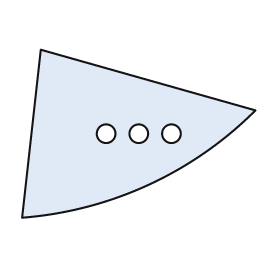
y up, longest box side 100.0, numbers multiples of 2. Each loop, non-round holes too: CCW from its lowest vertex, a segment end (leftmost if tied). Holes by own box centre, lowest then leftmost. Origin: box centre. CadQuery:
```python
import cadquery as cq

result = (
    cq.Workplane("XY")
    .moveTo(-50.0, -36.0)
    .threePointArc((4.0, -22.0), (50.0, 10.0))
    .lineTo(-42.0, 36.0)
    .close()
    .moveTo(-14.0, 0.0)
    .circle(4.0)
    .moveTo(0.0, 0.0)
    .circle(4.0)
    .moveTo(14.0, 0.0)
    .circle(4.0)
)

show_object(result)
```